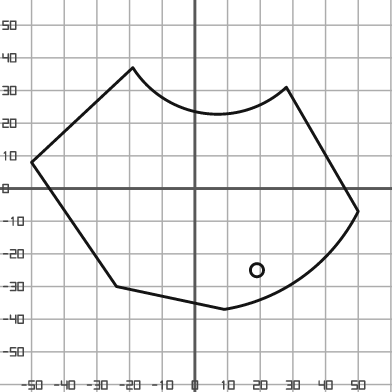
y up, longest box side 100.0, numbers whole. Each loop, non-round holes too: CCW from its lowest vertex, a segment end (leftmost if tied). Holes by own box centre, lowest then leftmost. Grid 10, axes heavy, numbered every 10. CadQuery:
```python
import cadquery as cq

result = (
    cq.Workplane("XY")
    .moveTo(9.0, -37.0)
    .threePointArc((33.0, -27.0), (50.0, -7.0))
    .lineTo(28.0, 31.0)
    .threePointArc((3.0, 23.0), (-19.0, 37.0))
    .lineTo(-50.0, 8.0)
    .lineTo(-24.0, -30.0)
    .close()
    .moveTo(19.0, -25.0)
    .circle(2.0)
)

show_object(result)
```